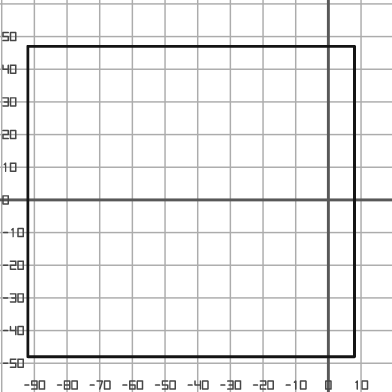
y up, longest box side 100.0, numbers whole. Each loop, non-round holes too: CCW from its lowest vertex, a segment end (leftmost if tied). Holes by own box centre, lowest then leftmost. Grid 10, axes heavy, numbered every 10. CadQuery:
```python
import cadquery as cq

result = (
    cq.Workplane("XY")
    .moveTo(-92.0, -48.0)
    .lineTo(8.0, -48.0)
    .lineTo(8.0, 47.0)
    .lineTo(-92.0, 47.0)
    .close()
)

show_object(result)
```